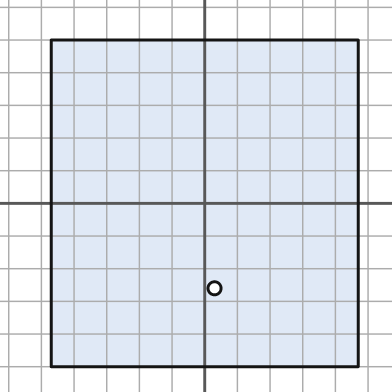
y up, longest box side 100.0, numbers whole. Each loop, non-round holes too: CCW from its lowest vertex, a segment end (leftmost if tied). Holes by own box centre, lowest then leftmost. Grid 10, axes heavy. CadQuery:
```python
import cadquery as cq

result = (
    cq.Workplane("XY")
    .moveTo(-47.0, -50.0)
    .lineTo(47.0, -50.0)
    .lineTo(47.0, 50.0)
    .lineTo(-47.0, 50.0)
    .close()
    .moveTo(3.0, -26.0)
    .circle(2.0)
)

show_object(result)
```